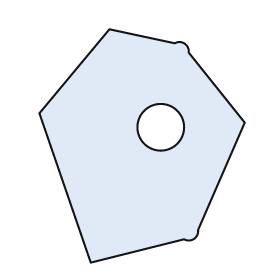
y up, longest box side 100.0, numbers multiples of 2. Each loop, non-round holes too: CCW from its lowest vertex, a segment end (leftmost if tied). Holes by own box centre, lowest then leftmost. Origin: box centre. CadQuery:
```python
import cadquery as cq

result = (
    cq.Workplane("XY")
    .moveTo(-22.0, -50.0)
    .lineTo(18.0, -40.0)
    .threePointArc((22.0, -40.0), (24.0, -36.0))
    .lineTo(44.0, 10.0)
    .lineTo(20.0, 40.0)
    .threePointArc((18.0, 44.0), (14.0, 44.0))
    .lineTo(-14.0, 50.0)
    .lineTo(-44.0, 14.0)
    .close()
    .moveTo(8.0, 8.0)
    .circle(10.0)
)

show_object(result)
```